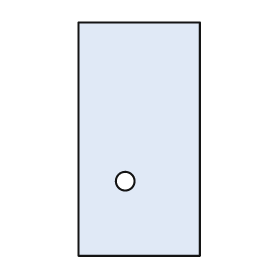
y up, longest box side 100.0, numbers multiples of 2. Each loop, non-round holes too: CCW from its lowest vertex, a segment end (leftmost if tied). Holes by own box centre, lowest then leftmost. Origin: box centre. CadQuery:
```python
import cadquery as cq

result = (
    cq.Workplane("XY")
    .moveTo(-26.0, -50.0)
    .lineTo(26.0, -50.0)
    .lineTo(26.0, 50.0)
    .lineTo(-26.0, 50.0)
    .close()
    .moveTo(-6.0, -18.0)
    .circle(4.0)
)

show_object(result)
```